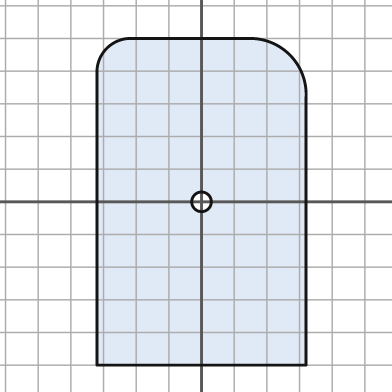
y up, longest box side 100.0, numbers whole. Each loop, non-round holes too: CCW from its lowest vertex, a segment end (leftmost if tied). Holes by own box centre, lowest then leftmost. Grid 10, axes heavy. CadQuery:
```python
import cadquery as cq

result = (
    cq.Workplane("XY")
    .moveTo(-32.0, -50.0)
    .lineTo(32.0, -50.0)
    .lineTo(32.0, 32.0)
    .threePointArc((27.0, 45.0), (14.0, 50.0))
    .lineTo(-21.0, 50.0)
    .threePointArc((-29.0, 47.0), (-32.0, 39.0))
    .close()
    .moveTo(0.0, 0.0)
    .circle(3.0)
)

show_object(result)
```